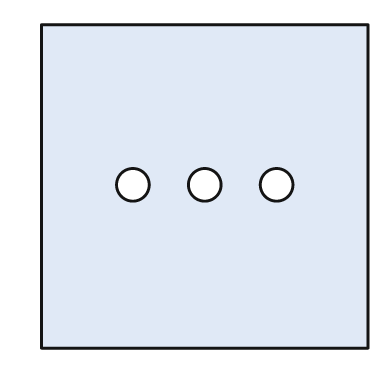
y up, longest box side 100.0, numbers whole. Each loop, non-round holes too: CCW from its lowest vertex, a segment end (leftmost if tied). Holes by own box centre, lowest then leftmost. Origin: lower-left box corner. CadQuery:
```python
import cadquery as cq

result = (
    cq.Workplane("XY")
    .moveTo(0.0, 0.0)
    .lineTo(100.0, 0.0)
    .lineTo(100.0, 99.0)
    .lineTo(0.0, 99.0)
    .close()
    .moveTo(28.0, 50.0)
    .circle(5.0)
    .moveTo(50.0, 50.0)
    .circle(5.0)
    .moveTo(72.0, 50.0)
    .circle(5.0)
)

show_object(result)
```